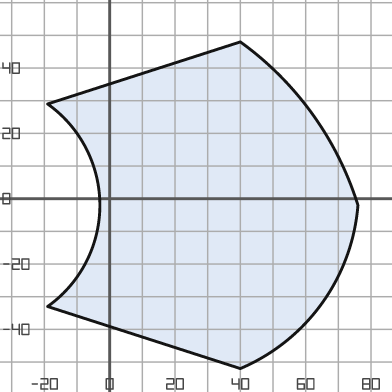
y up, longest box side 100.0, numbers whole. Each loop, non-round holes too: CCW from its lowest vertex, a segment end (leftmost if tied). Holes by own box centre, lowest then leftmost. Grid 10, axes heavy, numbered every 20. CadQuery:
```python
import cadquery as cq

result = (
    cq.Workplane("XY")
    .moveTo(40.0, -52.0)
    .threePointArc((65.0, -32.0), (76.0, -2.0))
    .threePointArc((62.0, 26.0), (40.0, 48.0))
    .lineTo(-19.0, 29.0)
    .threePointArc((-3.0, -2.0), (-19.0, -33.0))
    .close()
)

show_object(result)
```